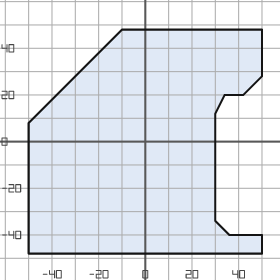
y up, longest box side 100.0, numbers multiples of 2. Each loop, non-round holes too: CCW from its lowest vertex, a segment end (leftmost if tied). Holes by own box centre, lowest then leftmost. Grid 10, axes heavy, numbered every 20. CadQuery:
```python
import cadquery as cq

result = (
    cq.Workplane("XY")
    .moveTo(-50.0, -48.0)
    .lineTo(50.0, -48.0)
    .lineTo(50.0, -40.0)
    .lineTo(36.0, -40.0)
    .lineTo(30.0, -34.0)
    .lineTo(30.0, 12.0)
    .lineTo(34.0, 20.0)
    .lineTo(42.0, 20.0)
    .lineTo(50.0, 28.0)
    .lineTo(50.0, 48.0)
    .lineTo(-10.0, 48.0)
    .lineTo(-50.0, 8.0)
    .close()
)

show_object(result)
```